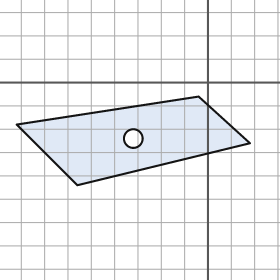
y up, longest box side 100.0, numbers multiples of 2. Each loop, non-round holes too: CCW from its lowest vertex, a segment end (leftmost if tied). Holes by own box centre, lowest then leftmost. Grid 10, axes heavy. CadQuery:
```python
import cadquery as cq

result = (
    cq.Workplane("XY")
    .moveTo(-56.0, -44.0)
    .lineTo(18.0, -26.0)
    .lineTo(-4.0, -6.0)
    .lineTo(-82.0, -18.0)
    .close()
    .moveTo(-32.0, -24.0)
    .circle(4.0)
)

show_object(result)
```